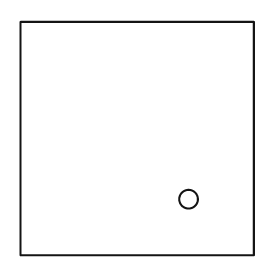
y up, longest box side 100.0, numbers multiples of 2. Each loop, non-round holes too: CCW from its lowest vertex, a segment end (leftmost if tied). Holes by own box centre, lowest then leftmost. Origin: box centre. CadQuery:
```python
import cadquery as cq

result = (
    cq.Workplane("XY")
    .moveTo(-50.0, -50.0)
    .lineTo(50.0, -50.0)
    .lineTo(50.0, 50.0)
    .lineTo(-50.0, 50.0)
    .close()
    .moveTo(22.0, -26.0)
    .circle(4.0)
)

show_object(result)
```